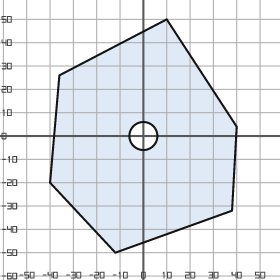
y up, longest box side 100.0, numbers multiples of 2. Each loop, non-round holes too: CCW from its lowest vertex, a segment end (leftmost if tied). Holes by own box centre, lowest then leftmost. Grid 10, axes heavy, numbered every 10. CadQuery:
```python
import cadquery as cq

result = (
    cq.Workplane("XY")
    .moveTo(-12.0, -50.0)
    .lineTo(38.0, -32.0)
    .lineTo(40.0, 4.0)
    .lineTo(10.0, 50.0)
    .lineTo(-36.0, 26.0)
    .lineTo(-40.0, -20.0)
    .close()
    .moveTo(0.0, 0.0)
    .circle(6.0)
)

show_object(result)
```